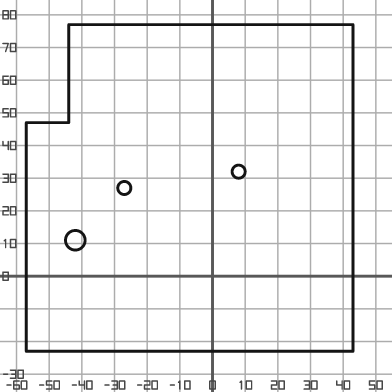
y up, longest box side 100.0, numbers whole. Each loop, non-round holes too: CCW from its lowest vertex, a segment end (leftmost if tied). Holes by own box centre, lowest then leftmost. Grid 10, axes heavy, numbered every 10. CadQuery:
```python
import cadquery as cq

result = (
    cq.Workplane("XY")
    .moveTo(-57.0, -23.0)
    .lineTo(43.0, -23.0)
    .lineTo(43.0, 77.0)
    .lineTo(-44.0, 77.0)
    .lineTo(-44.0, 47.0)
    .lineTo(-57.0, 47.0)
    .close()
    .moveTo(-42.0, 11.0)
    .circle(3.0)
    .moveTo(-27.0, 27.0)
    .circle(2.0)
    .moveTo(8.0, 32.0)
    .circle(2.0)
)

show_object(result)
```